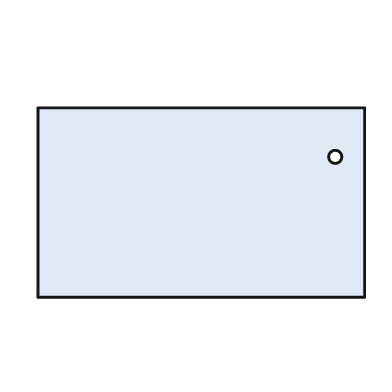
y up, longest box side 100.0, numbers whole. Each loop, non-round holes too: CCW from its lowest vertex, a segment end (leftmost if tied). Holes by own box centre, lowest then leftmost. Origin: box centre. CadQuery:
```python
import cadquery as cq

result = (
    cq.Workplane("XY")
    .moveTo(-50.0, -29.0)
    .lineTo(50.0, -29.0)
    .lineTo(50.0, 29.0)
    .lineTo(-50.0, 29.0)
    .close()
    .moveTo(41.0, 14.0)
    .circle(2.0)
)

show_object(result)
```